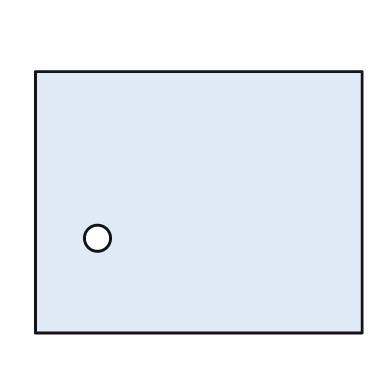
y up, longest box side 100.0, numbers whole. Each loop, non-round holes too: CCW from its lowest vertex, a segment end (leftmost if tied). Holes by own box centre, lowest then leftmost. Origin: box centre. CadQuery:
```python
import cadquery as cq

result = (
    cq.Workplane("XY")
    .moveTo(-50.0, -40.0)
    .lineTo(50.0, -40.0)
    .lineTo(50.0, 40.0)
    .lineTo(-50.0, 40.0)
    .close()
    .moveTo(-31.0, -11.0)
    .circle(4.0)
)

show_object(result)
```